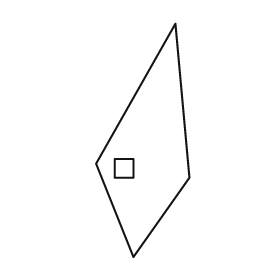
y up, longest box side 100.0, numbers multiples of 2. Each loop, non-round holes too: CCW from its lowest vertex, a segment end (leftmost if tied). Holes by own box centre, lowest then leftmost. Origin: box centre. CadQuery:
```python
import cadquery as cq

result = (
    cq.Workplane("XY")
    .moveTo(-4.0, -50.0)
    .lineTo(20.0, -16.0)
    .lineTo(14.0, 50.0)
    .lineTo(-20.0, -10.0)
    .close()
    .moveTo(-12.0, -16.0)
    .lineTo(-4.0, -16.0)
    .lineTo(-4.0, -8.0)
    .lineTo(-12.0, -8.0)
    .close()
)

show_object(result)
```